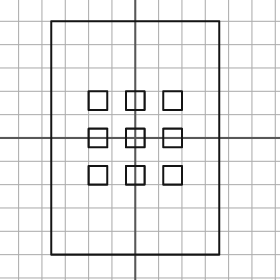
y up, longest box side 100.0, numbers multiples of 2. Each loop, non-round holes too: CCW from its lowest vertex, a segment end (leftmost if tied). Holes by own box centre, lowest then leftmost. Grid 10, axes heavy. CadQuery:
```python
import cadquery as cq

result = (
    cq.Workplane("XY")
    .moveTo(-36.0, -50.0)
    .lineTo(36.0, -50.0)
    .lineTo(36.0, 50.0)
    .lineTo(-36.0, 50.0)
    .close()
    .moveTo(-20.0, -20.0)
    .lineTo(-12.0, -20.0)
    .lineTo(-12.0, -12.0)
    .lineTo(-20.0, -12.0)
    .close()
    .moveTo(-4.0, -20.0)
    .lineTo(4.0, -20.0)
    .lineTo(4.0, -12.0)
    .lineTo(-4.0, -12.0)
    .close()
    .moveTo(12.0, -20.0)
    .lineTo(20.0, -20.0)
    .lineTo(20.0, -12.0)
    .lineTo(12.0, -12.0)
    .close()
    .moveTo(-20.0, -4.0)
    .lineTo(-12.0, -4.0)
    .lineTo(-12.0, 4.0)
    .lineTo(-20.0, 4.0)
    .close()
    .moveTo(-4.0, -4.0)
    .lineTo(4.0, -4.0)
    .lineTo(4.0, 4.0)
    .lineTo(-4.0, 4.0)
    .close()
    .moveTo(12.0, -4.0)
    .lineTo(20.0, -4.0)
    .lineTo(20.0, 4.0)
    .lineTo(12.0, 4.0)
    .close()
    .moveTo(-20.0, 12.0)
    .lineTo(-12.0, 12.0)
    .lineTo(-12.0, 20.0)
    .lineTo(-20.0, 20.0)
    .close()
    .moveTo(-4.0, 12.0)
    .lineTo(4.0, 12.0)
    .lineTo(4.0, 20.0)
    .lineTo(-4.0, 20.0)
    .close()
    .moveTo(12.0, 12.0)
    .lineTo(20.0, 12.0)
    .lineTo(20.0, 20.0)
    .lineTo(12.0, 20.0)
    .close()
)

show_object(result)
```